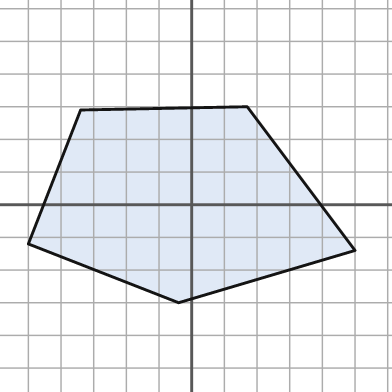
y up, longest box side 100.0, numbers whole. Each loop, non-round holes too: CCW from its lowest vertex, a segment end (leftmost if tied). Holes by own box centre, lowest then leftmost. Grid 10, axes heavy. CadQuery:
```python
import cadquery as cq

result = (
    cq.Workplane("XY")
    .moveTo(-4.0, -30.0)
    .lineTo(50.0, -14.0)
    .lineTo(17.0, 30.0)
    .lineTo(-34.0, 29.0)
    .lineTo(-50.0, -12.0)
    .close()
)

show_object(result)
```